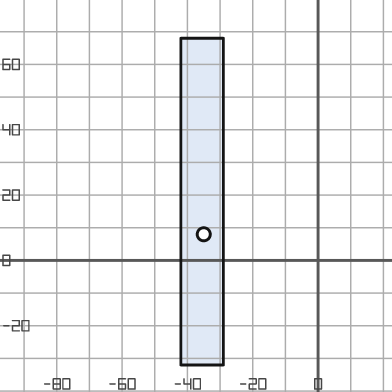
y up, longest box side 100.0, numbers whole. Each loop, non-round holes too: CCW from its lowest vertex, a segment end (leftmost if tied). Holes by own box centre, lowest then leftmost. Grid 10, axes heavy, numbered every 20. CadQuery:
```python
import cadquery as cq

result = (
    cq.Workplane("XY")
    .moveTo(-42.0, -32.0)
    .lineTo(-29.0, -32.0)
    .lineTo(-29.0, 68.0)
    .lineTo(-42.0, 68.0)
    .close()
    .moveTo(-35.0, 8.0)
    .circle(2.0)
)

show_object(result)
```